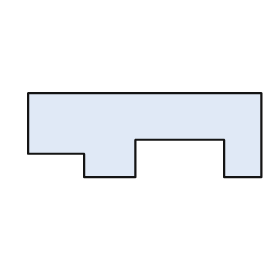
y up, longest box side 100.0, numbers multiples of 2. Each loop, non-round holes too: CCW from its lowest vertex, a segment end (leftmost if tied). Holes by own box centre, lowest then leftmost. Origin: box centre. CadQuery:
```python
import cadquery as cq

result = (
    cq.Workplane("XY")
    .moveTo(-26.0, -18.0)
    .lineTo(-4.0, -18.0)
    .lineTo(-4.0, -2.0)
    .lineTo(34.0, -2.0)
    .lineTo(34.0, -18.0)
    .lineTo(50.0, -18.0)
    .lineTo(50.0, 18.0)
    .lineTo(-50.0, 18.0)
    .lineTo(-50.0, -8.0)
    .lineTo(-26.0, -8.0)
    .close()
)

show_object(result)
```